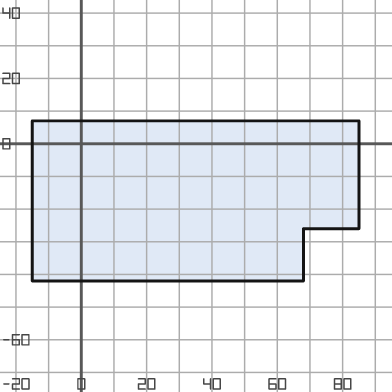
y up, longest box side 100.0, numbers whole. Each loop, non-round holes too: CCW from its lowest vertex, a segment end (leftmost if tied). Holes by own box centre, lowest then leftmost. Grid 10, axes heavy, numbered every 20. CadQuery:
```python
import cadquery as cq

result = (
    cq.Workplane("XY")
    .moveTo(-15.0, -42.0)
    .lineTo(68.0, -42.0)
    .lineTo(68.0, -26.0)
    .lineTo(85.0, -26.0)
    .lineTo(85.0, 7.0)
    .lineTo(-15.0, 7.0)
    .close()
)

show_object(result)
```